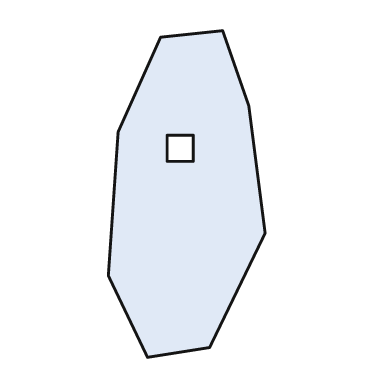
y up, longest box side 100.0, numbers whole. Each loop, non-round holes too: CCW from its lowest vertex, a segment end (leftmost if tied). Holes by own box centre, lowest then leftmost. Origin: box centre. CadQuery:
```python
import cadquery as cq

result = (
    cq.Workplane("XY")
    .moveTo(-12.0, -50.0)
    .lineTo(7.0, -47.0)
    .lineTo(24.0, -12.0)
    .lineTo(19.0, 27.0)
    .lineTo(11.0, 50.0)
    .lineTo(-8.0, 48.0)
    .lineTo(-21.0, 19.0)
    .lineTo(-24.0, -25.0)
    .close()
    .moveTo(-6.0, 10.0)
    .lineTo(2.0, 10.0)
    .lineTo(2.0, 18.0)
    .lineTo(-6.0, 18.0)
    .close()
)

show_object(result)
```